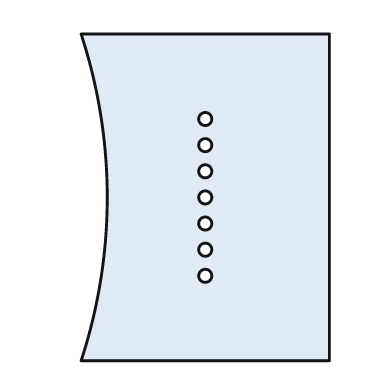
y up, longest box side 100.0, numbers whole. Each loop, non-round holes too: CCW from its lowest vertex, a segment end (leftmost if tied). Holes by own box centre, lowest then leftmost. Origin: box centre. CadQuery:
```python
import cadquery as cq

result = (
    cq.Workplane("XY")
    .moveTo(-38.0, -50.0)
    .lineTo(38.0, -50.0)
    .lineTo(38.0, 50.0)
    .lineTo(-38.0, 50.0)
    .threePointArc((-30.0, 0.0), (-38.0, -50.0))
    .close()
    .moveTo(0.0, -24.0)
    .circle(2.0)
    .moveTo(0.0, -16.0)
    .circle(2.0)
    .moveTo(0.0, -8.0)
    .circle(2.0)
    .moveTo(0.0, 0.0)
    .circle(2.0)
    .moveTo(0.0, 8.0)
    .circle(2.0)
    .moveTo(0.0, 16.0)
    .circle(2.0)
    .moveTo(0.0, 24.0)
    .circle(2.0)
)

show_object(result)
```